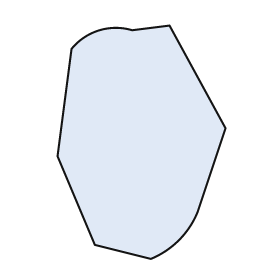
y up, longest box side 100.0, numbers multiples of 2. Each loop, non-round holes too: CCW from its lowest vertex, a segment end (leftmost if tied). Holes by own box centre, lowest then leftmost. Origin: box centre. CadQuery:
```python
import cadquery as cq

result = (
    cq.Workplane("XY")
    .moveTo(4.0, -50.0)
    .threePointArc((16.0, -42.0), (24.0, -30.0))
    .lineTo(36.0, 6.0)
    .lineTo(12.0, 50.0)
    .lineTo(-4.0, 48.0)
    .threePointArc((-18.0, 48.0), (-30.0, 40.0))
    .lineTo(-36.0, -6.0)
    .lineTo(-20.0, -44.0)
    .close()
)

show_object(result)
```